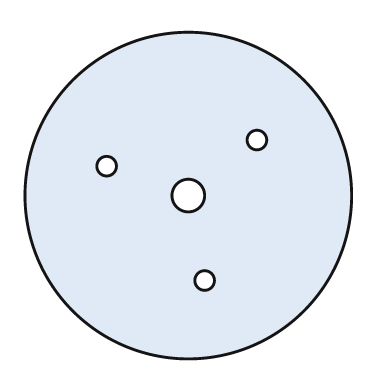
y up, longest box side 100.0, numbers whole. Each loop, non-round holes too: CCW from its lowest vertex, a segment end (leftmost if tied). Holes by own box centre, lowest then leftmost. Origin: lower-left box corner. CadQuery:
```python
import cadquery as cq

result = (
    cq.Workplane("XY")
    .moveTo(50.0, 50.0)
    .circle(50.0)
    .moveTo(55.0, 24.0)
    .circle(3.0)
    .moveTo(50.0, 50.0)
    .circle(5.0)
    .moveTo(25.0, 59.0)
    .circle(3.0)
    .moveTo(71.0, 67.0)
    .circle(3.0)
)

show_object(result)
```